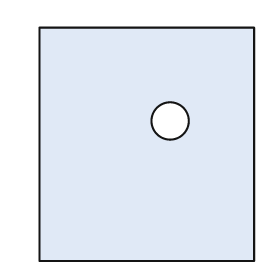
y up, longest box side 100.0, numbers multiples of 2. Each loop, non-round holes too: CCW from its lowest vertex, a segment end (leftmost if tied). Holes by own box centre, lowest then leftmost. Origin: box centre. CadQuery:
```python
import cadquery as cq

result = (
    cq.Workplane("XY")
    .moveTo(-46.0, -50.0)
    .lineTo(46.0, -50.0)
    .lineTo(46.0, 50.0)
    .lineTo(-46.0, 50.0)
    .close()
    .moveTo(10.0, 10.0)
    .circle(8.0)
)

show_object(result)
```